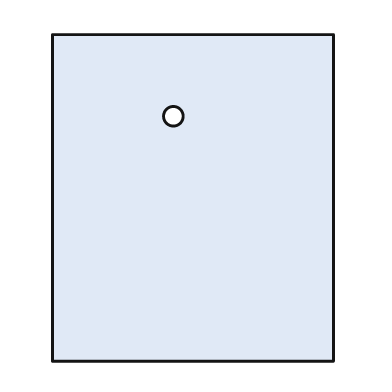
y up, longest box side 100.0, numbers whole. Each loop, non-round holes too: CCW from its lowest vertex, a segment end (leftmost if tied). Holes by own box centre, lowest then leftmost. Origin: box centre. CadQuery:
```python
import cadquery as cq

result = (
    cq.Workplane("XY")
    .moveTo(-43.0, -50.0)
    .lineTo(43.0, -50.0)
    .lineTo(43.0, 50.0)
    .lineTo(-43.0, 50.0)
    .close()
    .moveTo(-6.0, 25.0)
    .circle(3.0)
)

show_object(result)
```